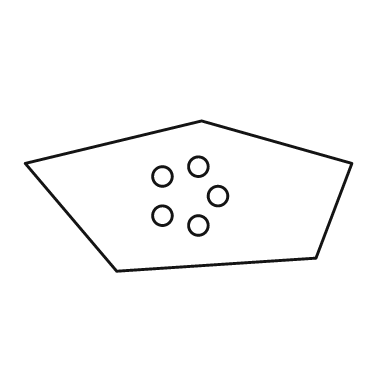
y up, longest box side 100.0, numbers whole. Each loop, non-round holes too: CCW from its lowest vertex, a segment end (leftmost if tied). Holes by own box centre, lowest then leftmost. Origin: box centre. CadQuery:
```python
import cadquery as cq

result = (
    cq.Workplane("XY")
    .moveTo(-22.0, -23.0)
    .lineTo(39.0, -19.0)
    .lineTo(50.0, 10.0)
    .lineTo(4.0, 23.0)
    .lineTo(-50.0, 10.0)
    .close()
    .moveTo(3.0, -9.0)
    .circle(3.0)
    .moveTo(-8.0, -6.0)
    .circle(3.0)
    .moveTo(9.0, 0.0)
    .circle(3.0)
    .moveTo(-8.0, 6.0)
    .circle(3.0)
    .moveTo(3.0, 9.0)
    .circle(3.0)
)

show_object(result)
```